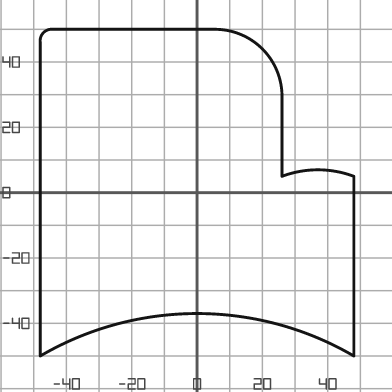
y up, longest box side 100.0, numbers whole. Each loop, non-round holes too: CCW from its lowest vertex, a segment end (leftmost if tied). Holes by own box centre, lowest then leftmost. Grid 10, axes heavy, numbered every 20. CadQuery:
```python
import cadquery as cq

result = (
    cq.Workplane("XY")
    .moveTo(-48.0, -50.0)
    .threePointArc((0.0, -37.0), (48.0, -50.0))
    .lineTo(48.0, 5.0)
    .threePointArc((37.0, 7.0), (26.0, 5.0))
    .lineTo(26.0, 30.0)
    .threePointArc((20.0, 44.0), (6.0, 50.0))
    .lineTo(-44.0, 50.0)
    .threePointArc((-47.0, 49.0), (-48.0, 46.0))
    .close()
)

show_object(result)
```